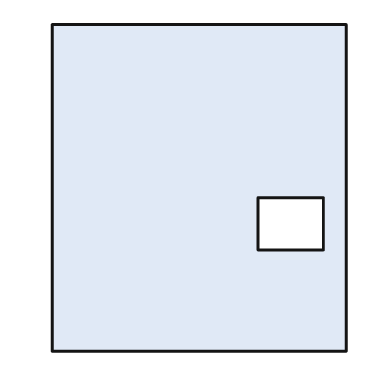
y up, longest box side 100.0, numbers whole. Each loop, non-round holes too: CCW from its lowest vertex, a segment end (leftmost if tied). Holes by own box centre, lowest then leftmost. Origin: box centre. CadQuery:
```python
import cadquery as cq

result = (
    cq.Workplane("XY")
    .moveTo(-45.0, -50.0)
    .lineTo(45.0, -50.0)
    .lineTo(45.0, 50.0)
    .lineTo(-45.0, 50.0)
    .close()
    .moveTo(18.0, -19.0)
    .lineTo(38.0, -19.0)
    .lineTo(38.0, -3.0)
    .lineTo(18.0, -3.0)
    .close()
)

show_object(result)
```